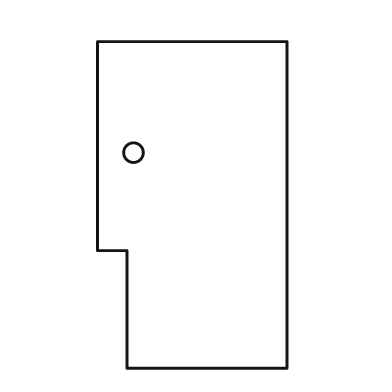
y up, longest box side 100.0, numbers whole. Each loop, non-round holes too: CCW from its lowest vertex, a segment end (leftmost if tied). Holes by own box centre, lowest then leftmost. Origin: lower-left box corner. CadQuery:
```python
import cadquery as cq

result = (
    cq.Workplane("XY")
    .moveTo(9.0, 0.0)
    .lineTo(58.0, 0.0)
    .lineTo(58.0, 100.0)
    .lineTo(0.0, 100.0)
    .lineTo(0.0, 36.0)
    .lineTo(9.0, 36.0)
    .close()
    .moveTo(11.0, 66.0)
    .circle(3.0)
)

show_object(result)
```